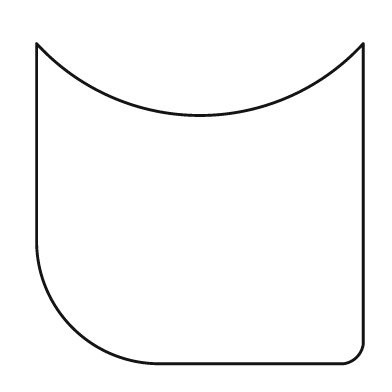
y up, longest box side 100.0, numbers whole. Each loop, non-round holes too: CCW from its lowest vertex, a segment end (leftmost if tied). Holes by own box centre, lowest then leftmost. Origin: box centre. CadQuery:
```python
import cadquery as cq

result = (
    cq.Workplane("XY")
    .moveTo(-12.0, -49.0)
    .lineTo(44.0, -49.0)
    .threePointArc((48.0, -47.0), (50.0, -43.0))
    .lineTo(50.0, 49.0)
    .threePointArc((0.0, 27.0), (-50.0, 49.0))
    .lineTo(-50.0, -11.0)
    .threePointArc((-39.0, -38.0), (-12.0, -49.0))
    .close()
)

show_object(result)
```